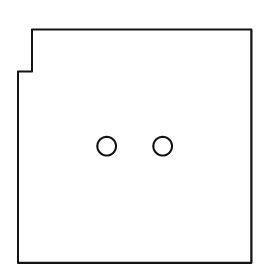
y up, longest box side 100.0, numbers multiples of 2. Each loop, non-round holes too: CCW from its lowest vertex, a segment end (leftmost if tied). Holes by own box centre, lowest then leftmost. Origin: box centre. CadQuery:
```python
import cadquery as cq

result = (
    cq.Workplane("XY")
    .moveTo(-50.0, -50.0)
    .lineTo(50.0, -50.0)
    .lineTo(50.0, 50.0)
    .lineTo(-44.0, 50.0)
    .lineTo(-44.0, 32.0)
    .lineTo(-50.0, 32.0)
    .close()
    .moveTo(-12.0, 0.0)
    .circle(4.0)
    .moveTo(12.0, 0.0)
    .circle(4.0)
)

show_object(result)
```